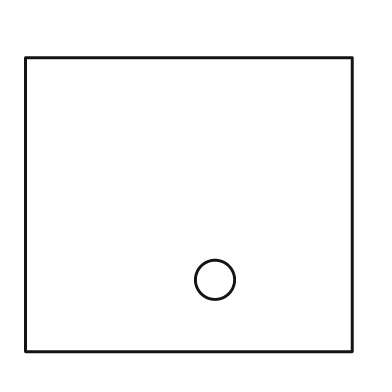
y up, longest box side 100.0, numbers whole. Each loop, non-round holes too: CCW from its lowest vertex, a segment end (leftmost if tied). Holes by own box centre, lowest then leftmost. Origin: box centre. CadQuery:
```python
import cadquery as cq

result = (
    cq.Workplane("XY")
    .moveTo(-50.0, -45.0)
    .lineTo(50.0, -45.0)
    .lineTo(50.0, 45.0)
    .lineTo(-50.0, 45.0)
    .close()
    .moveTo(8.0, -23.0)
    .circle(6.0)
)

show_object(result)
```